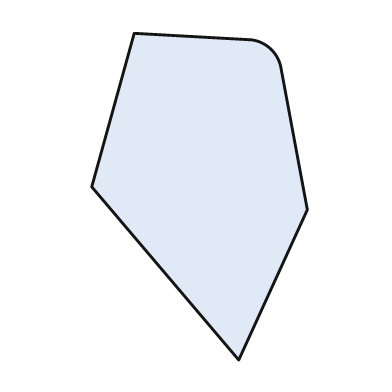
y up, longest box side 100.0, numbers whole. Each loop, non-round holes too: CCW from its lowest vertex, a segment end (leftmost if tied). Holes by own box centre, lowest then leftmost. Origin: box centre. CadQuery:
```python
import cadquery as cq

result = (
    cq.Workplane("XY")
    .moveTo(12.0, -50.0)
    .lineTo(33.0, -4.0)
    .lineTo(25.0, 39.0)
    .threePointArc((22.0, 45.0), (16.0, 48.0))
    .lineTo(-20.0, 50.0)
    .lineTo(-33.0, 3.0)
    .close()
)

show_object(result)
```